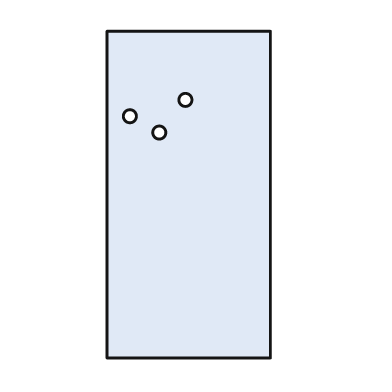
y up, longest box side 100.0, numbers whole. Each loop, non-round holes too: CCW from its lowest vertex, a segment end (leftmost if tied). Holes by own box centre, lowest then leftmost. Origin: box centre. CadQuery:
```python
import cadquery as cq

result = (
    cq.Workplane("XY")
    .moveTo(-25.0, -50.0)
    .lineTo(25.0, -50.0)
    .lineTo(25.0, 50.0)
    .lineTo(-25.0, 50.0)
    .close()
    .moveTo(-9.0, 19.0)
    .circle(2.0)
    .moveTo(-18.0, 24.0)
    .circle(2.0)
    .moveTo(-1.0, 29.0)
    .circle(2.0)
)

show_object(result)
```